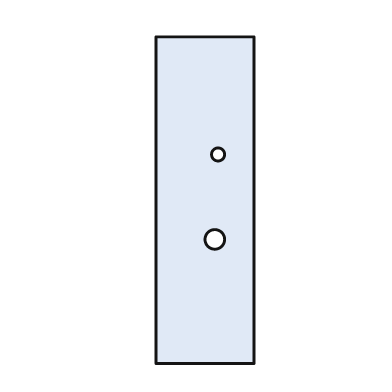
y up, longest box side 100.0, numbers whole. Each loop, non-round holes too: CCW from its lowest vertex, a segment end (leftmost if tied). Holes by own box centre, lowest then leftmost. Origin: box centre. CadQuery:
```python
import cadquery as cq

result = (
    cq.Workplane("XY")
    .moveTo(-15.0, -50.0)
    .lineTo(15.0, -50.0)
    .lineTo(15.0, 50.0)
    .lineTo(-15.0, 50.0)
    .close()
    .moveTo(3.0, -12.0)
    .circle(3.0)
    .moveTo(4.0, 14.0)
    .circle(2.0)
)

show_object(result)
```